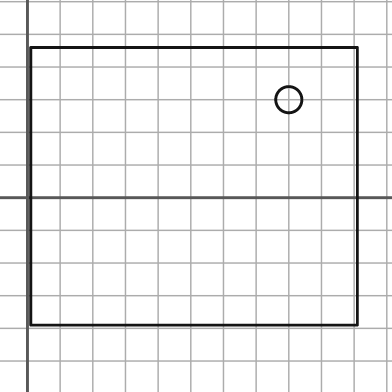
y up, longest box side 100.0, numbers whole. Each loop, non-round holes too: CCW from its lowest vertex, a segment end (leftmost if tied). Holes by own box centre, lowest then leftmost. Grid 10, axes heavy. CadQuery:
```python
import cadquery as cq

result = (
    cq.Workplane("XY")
    .moveTo(1.0, -39.0)
    .lineTo(101.0, -39.0)
    .lineTo(101.0, 46.0)
    .lineTo(1.0, 46.0)
    .close()
    .moveTo(80.0, 30.0)
    .circle(4.0)
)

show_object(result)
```